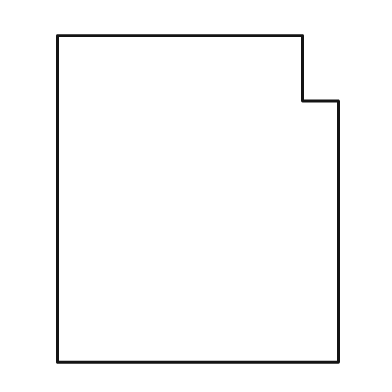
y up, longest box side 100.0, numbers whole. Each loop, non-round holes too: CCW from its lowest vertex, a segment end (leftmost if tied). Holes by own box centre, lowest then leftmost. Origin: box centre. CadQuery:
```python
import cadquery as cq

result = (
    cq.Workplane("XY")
    .moveTo(-43.0, -50.0)
    .lineTo(43.0, -50.0)
    .lineTo(43.0, 30.0)
    .lineTo(32.0, 30.0)
    .lineTo(32.0, 50.0)
    .lineTo(-43.0, 50.0)
    .close()
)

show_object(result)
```